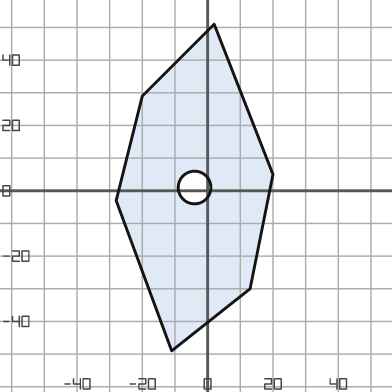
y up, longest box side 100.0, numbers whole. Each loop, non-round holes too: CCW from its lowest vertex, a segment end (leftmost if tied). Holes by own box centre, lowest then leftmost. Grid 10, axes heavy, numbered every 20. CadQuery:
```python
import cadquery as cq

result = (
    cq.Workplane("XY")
    .moveTo(-11.0, -49.0)
    .lineTo(13.0, -30.0)
    .lineTo(20.0, 5.0)
    .lineTo(2.0, 51.0)
    .lineTo(-20.0, 29.0)
    .lineTo(-28.0, -3.0)
    .close()
    .moveTo(-4.0, 1.0)
    .circle(5.0)
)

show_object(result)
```